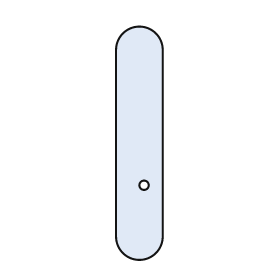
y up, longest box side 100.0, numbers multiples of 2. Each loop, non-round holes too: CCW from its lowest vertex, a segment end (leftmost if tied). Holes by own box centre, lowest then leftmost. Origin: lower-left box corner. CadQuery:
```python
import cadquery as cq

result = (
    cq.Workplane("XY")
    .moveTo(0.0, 10.0)
    .threePointArc((10.0, 0.0), (20.0, 10.0))
    .lineTo(20.0, 90.0)
    .threePointArc((10.0, 100.0), (0.0, 90.0))
    .close()
    .moveTo(12.0, 32.0)
    .circle(2.0)
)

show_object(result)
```